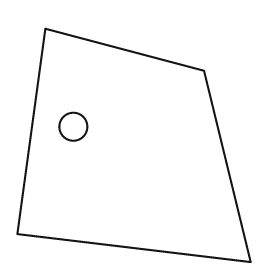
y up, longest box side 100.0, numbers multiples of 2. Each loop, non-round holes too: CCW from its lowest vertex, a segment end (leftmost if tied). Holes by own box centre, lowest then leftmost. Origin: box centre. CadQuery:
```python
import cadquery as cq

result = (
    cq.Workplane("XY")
    .moveTo(50.0, -50.0)
    .lineTo(30.0, 32.0)
    .lineTo(-38.0, 50.0)
    .lineTo(-50.0, -38.0)
    .close()
    .moveTo(-26.0, 8.0)
    .circle(6.0)
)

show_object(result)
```